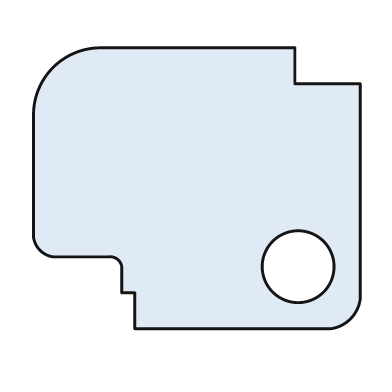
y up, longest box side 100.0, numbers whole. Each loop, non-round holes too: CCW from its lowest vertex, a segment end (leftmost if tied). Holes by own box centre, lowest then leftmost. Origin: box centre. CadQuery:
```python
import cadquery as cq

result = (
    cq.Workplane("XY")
    .moveTo(-19.0, -43.0)
    .lineTo(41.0, -43.0)
    .threePointArc((47.0, -40.0), (50.0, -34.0))
    .lineTo(50.0, 32.0)
    .lineTo(30.0, 32.0)
    .lineTo(30.0, 43.0)
    .lineTo(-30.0, 43.0)
    .threePointArc((-44.0, 37.0), (-50.0, 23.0))
    .lineTo(-50.0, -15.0)
    .threePointArc((-48.0, -19.0), (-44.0, -21.0))
    .lineTo(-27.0, -21.0)
    .threePointArc((-24.0, -22.0), (-23.0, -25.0))
    .lineTo(-23.0, -32.0)
    .lineTo(-19.0, -32.0)
    .close()
    .moveTo(31.0, -24.0)
    .circle(11.0)
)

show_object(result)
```